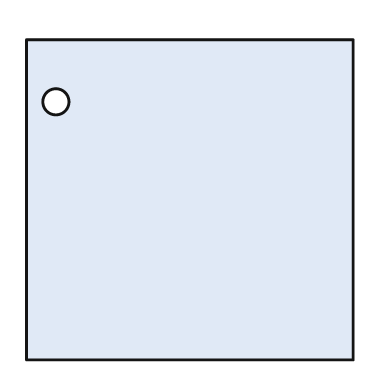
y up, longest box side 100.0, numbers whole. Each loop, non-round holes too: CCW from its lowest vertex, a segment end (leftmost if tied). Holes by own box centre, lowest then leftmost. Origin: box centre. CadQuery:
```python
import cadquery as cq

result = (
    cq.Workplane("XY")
    .moveTo(-50.0, -49.0)
    .lineTo(50.0, -49.0)
    .lineTo(50.0, 49.0)
    .lineTo(-50.0, 49.0)
    .close()
    .moveTo(-41.0, 30.0)
    .circle(4.0)
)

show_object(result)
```